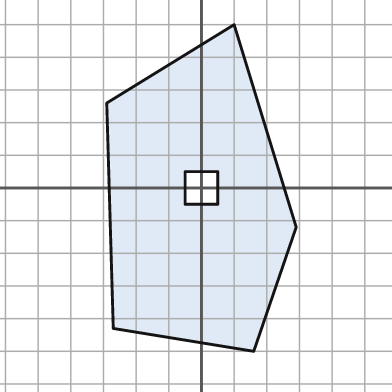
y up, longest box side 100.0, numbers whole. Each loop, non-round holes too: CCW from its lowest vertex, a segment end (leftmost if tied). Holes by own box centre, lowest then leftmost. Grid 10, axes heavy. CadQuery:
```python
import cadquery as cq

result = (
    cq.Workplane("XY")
    .moveTo(16.0, -50.0)
    .lineTo(29.0, -12.0)
    .lineTo(10.0, 50.0)
    .lineTo(-29.0, 26.0)
    .lineTo(-27.0, -43.0)
    .close()
    .moveTo(-5.0, -5.0)
    .lineTo(5.0, -5.0)
    .lineTo(5.0, 5.0)
    .lineTo(-5.0, 5.0)
    .close()
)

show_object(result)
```